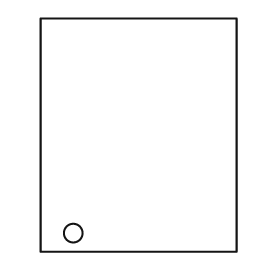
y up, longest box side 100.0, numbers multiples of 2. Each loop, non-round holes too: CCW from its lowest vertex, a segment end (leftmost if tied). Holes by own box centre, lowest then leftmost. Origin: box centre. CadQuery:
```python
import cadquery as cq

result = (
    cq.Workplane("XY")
    .moveTo(-42.0, -50.0)
    .lineTo(42.0, -50.0)
    .lineTo(42.0, 50.0)
    .lineTo(-42.0, 50.0)
    .close()
    .moveTo(-28.0, -42.0)
    .circle(4.0)
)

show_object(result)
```